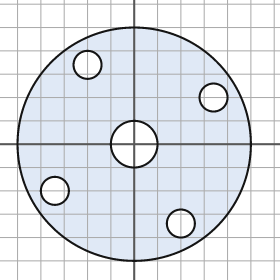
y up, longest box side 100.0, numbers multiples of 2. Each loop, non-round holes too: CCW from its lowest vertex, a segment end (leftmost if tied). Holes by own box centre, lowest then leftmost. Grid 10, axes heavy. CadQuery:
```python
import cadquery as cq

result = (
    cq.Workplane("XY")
    .moveTo(0.0, 0.0)
    .circle(50.0)
    .moveTo(20.0, -34.0)
    .circle(6.0)
    .moveTo(-34.0, -20.0)
    .circle(6.0)
    .moveTo(0.0, 0.0)
    .circle(10.0)
    .moveTo(34.0, 20.0)
    .circle(6.0)
    .moveTo(-20.0, 34.0)
    .circle(6.0)
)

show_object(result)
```